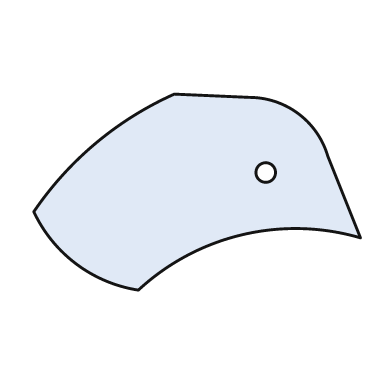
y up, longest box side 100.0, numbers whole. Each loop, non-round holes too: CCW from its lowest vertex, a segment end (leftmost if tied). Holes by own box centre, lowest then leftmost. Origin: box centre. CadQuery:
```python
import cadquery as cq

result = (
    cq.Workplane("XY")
    .moveTo(-18.0, -30.0)
    .threePointArc((14.0, -13.0), (50.0, -14.0))
    .lineTo(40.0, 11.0)
    .threePointArc((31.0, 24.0), (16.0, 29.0))
    .lineTo(-7.0, 30.0)
    .threePointArc((-31.0, 15.0), (-50.0, -6.0))
    .threePointArc((-37.0, -22.0), (-18.0, -30.0))
    .close()
    .moveTo(21.0, 6.0)
    .circle(3.0)
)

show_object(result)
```